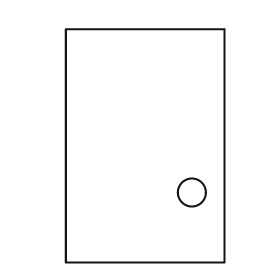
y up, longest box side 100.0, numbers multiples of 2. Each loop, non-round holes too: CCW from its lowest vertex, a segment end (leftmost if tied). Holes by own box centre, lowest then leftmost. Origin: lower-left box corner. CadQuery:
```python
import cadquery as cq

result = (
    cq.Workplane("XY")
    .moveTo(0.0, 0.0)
    .lineTo(68.0, 0.0)
    .lineTo(68.0, 100.0)
    .lineTo(0.0, 100.0)
    .close()
    .moveTo(54.0, 30.0)
    .circle(6.0)
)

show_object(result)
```